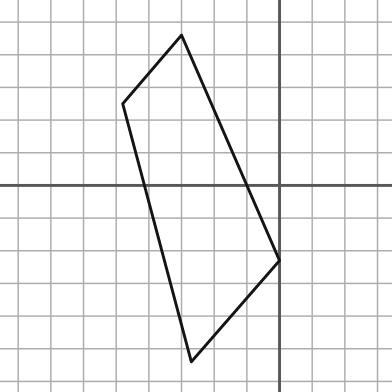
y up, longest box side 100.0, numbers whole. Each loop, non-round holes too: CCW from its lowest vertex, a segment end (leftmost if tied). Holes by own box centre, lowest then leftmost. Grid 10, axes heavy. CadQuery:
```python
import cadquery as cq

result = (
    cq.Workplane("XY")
    .moveTo(-27.0, -54.0)
    .lineTo(0.0, -23.0)
    .lineTo(-30.0, 46.0)
    .lineTo(-48.0, 25.0)
    .close()
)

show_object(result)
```